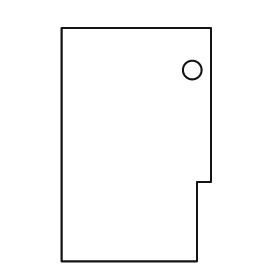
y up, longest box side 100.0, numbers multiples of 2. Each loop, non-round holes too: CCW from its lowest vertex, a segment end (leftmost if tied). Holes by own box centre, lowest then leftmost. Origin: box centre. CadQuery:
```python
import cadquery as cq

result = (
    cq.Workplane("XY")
    .moveTo(-32.0, -50.0)
    .lineTo(26.0, -50.0)
    .lineTo(26.0, -16.0)
    .lineTo(32.0, -16.0)
    .lineTo(32.0, 50.0)
    .lineTo(-32.0, 50.0)
    .close()
    .moveTo(24.0, 32.0)
    .circle(4.0)
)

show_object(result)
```